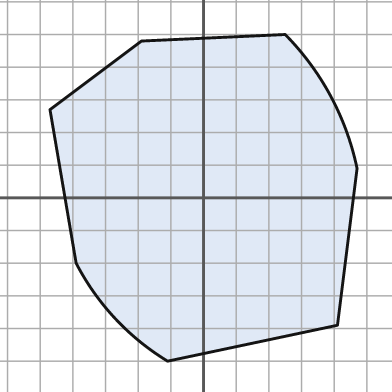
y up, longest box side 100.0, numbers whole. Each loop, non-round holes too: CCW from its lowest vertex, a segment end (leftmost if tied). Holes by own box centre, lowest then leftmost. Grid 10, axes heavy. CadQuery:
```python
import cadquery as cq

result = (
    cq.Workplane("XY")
    .moveTo(-11.0, -50.0)
    .lineTo(41.0, -39.0)
    .lineTo(47.0, 9.0)
    .threePointArc((39.0, 31.0), (25.0, 50.0))
    .lineTo(-19.0, 48.0)
    .lineTo(-47.0, 27.0)
    .lineTo(-39.0, -20.0)
    .threePointArc((-27.0, -37.0), (-11.0, -50.0))
    .close()
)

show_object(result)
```